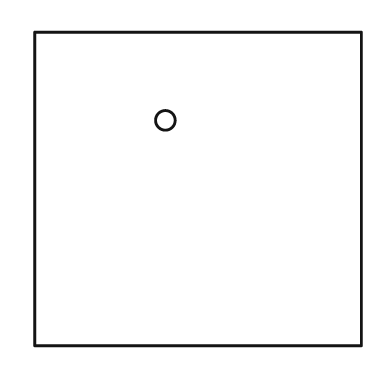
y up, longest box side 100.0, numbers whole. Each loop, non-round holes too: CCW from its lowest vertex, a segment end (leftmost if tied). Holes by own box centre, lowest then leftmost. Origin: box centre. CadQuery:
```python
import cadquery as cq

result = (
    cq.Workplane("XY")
    .moveTo(-50.0, -48.0)
    .lineTo(50.0, -48.0)
    .lineTo(50.0, 48.0)
    .lineTo(-50.0, 48.0)
    .close()
    .moveTo(-10.0, 21.0)
    .circle(3.0)
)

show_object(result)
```